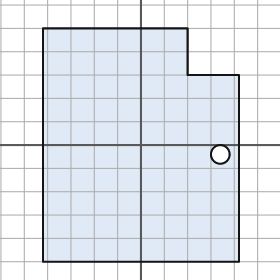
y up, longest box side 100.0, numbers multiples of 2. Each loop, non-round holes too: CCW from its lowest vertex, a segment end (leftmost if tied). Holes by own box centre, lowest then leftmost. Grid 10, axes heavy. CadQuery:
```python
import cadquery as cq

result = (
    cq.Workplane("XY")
    .moveTo(-42.0, -50.0)
    .lineTo(42.0, -50.0)
    .lineTo(42.0, 30.0)
    .lineTo(20.0, 30.0)
    .lineTo(20.0, 50.0)
    .lineTo(-42.0, 50.0)
    .close()
    .moveTo(34.0, -4.0)
    .circle(4.0)
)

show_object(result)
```